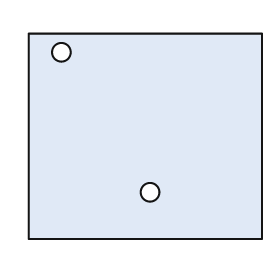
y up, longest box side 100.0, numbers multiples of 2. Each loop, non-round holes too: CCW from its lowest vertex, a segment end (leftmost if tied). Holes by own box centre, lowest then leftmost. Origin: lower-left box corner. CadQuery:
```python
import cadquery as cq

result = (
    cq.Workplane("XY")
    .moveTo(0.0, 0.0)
    .lineTo(100.0, 0.0)
    .lineTo(100.0, 88.0)
    .lineTo(0.0, 88.0)
    .close()
    .moveTo(52.0, 20.0)
    .circle(4.0)
    .moveTo(14.0, 80.0)
    .circle(4.0)
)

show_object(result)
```